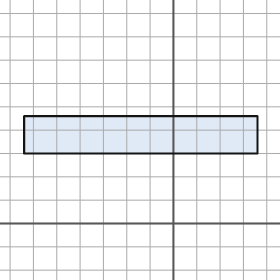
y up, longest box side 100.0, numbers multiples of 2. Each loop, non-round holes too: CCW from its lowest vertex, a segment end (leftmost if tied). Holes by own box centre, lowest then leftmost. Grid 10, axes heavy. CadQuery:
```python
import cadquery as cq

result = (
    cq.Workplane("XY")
    .moveTo(-64.0, 30.0)
    .lineTo(36.0, 30.0)
    .lineTo(36.0, 46.0)
    .lineTo(-64.0, 46.0)
    .close()
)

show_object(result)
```